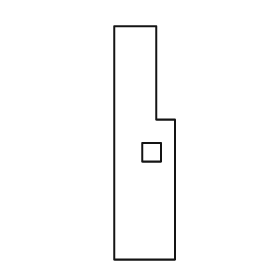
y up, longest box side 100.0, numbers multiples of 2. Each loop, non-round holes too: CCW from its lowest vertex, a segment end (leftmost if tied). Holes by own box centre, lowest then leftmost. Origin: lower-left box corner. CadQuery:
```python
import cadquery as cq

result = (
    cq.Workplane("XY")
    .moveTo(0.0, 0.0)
    .lineTo(26.0, 0.0)
    .lineTo(26.0, 60.0)
    .lineTo(18.0, 60.0)
    .lineTo(18.0, 100.0)
    .lineTo(0.0, 100.0)
    .close()
    .moveTo(12.0, 42.0)
    .lineTo(20.0, 42.0)
    .lineTo(20.0, 50.0)
    .lineTo(12.0, 50.0)
    .close()
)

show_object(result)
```